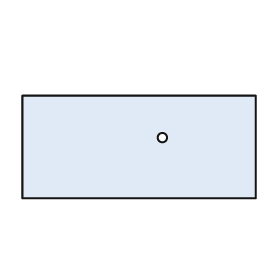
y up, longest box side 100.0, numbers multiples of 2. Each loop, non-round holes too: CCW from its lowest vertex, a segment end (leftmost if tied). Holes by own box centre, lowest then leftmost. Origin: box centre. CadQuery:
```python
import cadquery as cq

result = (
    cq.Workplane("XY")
    .moveTo(-50.0, -22.0)
    .lineTo(50.0, -22.0)
    .lineTo(50.0, 22.0)
    .lineTo(-50.0, 22.0)
    .close()
    .moveTo(10.0, 4.0)
    .circle(2.0)
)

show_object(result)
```